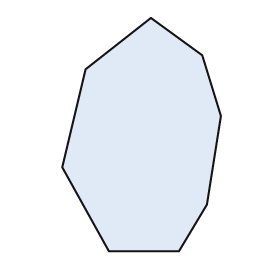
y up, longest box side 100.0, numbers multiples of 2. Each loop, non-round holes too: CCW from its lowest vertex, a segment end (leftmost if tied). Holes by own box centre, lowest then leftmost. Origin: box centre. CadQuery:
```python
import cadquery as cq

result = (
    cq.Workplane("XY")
    .moveTo(-14.0, -50.0)
    .lineTo(16.0, -50.0)
    .lineTo(28.0, -30.0)
    .lineTo(34.0, 8.0)
    .lineTo(26.0, 34.0)
    .lineTo(4.0, 50.0)
    .lineTo(-24.0, 28.0)
    .lineTo(-34.0, -14.0)
    .close()
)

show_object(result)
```